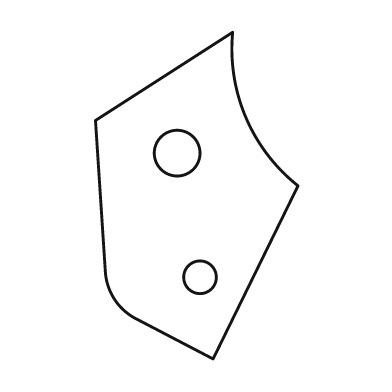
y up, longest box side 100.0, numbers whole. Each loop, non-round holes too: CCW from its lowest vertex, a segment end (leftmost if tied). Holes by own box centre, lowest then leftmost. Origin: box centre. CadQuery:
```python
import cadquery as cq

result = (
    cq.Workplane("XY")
    .moveTo(5.0, -50.0)
    .lineTo(31.0, 3.0)
    .threePointArc((15.0, 24.0), (11.0, 50.0))
    .lineTo(-31.0, 23.0)
    .lineTo(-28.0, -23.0)
    .threePointArc((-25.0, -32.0), (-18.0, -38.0))
    .close()
    .moveTo(1.0, -25.0)
    .circle(5.0)
    .moveTo(-6.0, 13.0)
    .circle(7.0)
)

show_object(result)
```